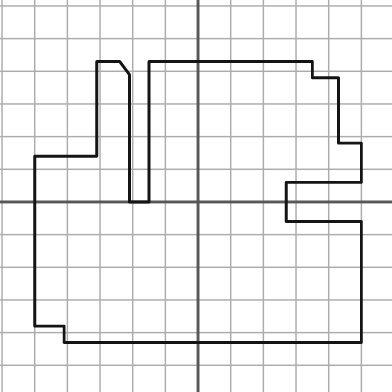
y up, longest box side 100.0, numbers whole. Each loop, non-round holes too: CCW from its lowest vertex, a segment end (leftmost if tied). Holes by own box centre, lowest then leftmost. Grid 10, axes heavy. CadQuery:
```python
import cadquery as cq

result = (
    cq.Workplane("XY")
    .moveTo(-41.0, -43.0)
    .lineTo(50.0, -43.0)
    .lineTo(50.0, -6.0)
    .lineTo(27.0, -6.0)
    .lineTo(27.0, 6.0)
    .lineTo(50.0, 6.0)
    .lineTo(50.0, 18.0)
    .lineTo(43.0, 18.0)
    .lineTo(43.0, 38.0)
    .lineTo(35.0, 38.0)
    .lineTo(35.0, 43.0)
    .lineTo(-15.0, 43.0)
    .lineTo(-15.0, 0.0)
    .lineTo(-21.0, 0.0)
    .lineTo(-21.0, 39.0)
    .lineTo(-24.0, 43.0)
    .lineTo(-31.0, 43.0)
    .lineTo(-31.0, 14.0)
    .lineTo(-50.0, 14.0)
    .lineTo(-50.0, -38.0)
    .lineTo(-41.0, -38.0)
    .close()
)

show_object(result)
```